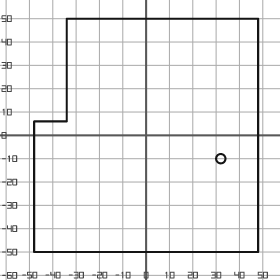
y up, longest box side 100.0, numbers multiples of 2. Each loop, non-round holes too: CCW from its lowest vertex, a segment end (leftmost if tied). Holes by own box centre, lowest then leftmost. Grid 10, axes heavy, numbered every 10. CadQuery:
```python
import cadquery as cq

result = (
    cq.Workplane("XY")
    .moveTo(-48.0, -50.0)
    .lineTo(48.0, -50.0)
    .lineTo(48.0, 50.0)
    .lineTo(-34.0, 50.0)
    .lineTo(-34.0, 6.0)
    .lineTo(-48.0, 6.0)
    .close()
    .moveTo(32.0, -10.0)
    .circle(2.0)
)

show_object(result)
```